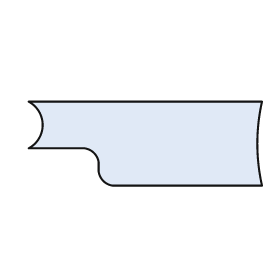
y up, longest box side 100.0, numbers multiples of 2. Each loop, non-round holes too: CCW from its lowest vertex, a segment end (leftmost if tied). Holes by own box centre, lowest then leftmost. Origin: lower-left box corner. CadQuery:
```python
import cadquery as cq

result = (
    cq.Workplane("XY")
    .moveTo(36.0, 0.0)
    .lineTo(100.0, 0.0)
    .threePointArc((98.0, 18.0), (100.0, 36.0))
    .lineTo(0.0, 36.0)
    .threePointArc((6.0, 26.0), (0.0, 16.0))
    .lineTo(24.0, 16.0)
    .threePointArc((28.0, 14.0), (30.0, 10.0))
    .lineTo(30.0, 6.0)
    .threePointArc((32.0, 2.0), (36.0, 0.0))
    .close()
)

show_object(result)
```